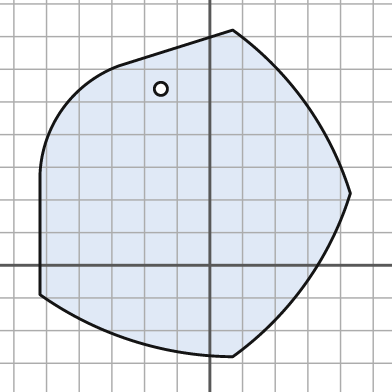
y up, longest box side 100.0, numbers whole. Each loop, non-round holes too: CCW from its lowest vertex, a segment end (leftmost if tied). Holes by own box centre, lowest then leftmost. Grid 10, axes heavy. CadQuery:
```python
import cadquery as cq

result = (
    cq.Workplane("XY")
    .moveTo(7.0, -28.0)
    .threePointArc((29.0, -6.0), (43.0, 22.0))
    .threePointArc((29.0, 50.0), (7.0, 72.0))
    .lineTo(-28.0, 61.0)
    .threePointArc((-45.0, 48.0), (-52.0, 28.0))
    .lineTo(-52.0, -9.0)
    .threePointArc((-24.0, -23.0), (7.0, -28.0))
    .close()
    .moveTo(-15.0, 54.0)
    .circle(2.0)
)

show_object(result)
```